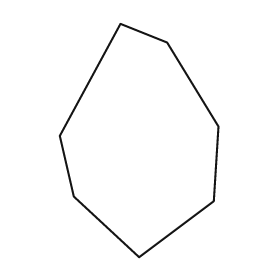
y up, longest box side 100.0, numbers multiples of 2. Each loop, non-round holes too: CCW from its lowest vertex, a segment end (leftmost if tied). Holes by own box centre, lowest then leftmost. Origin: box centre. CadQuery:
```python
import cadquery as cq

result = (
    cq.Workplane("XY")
    .moveTo(0.0, -50.0)
    .lineTo(32.0, -26.0)
    .lineTo(34.0, 6.0)
    .lineTo(12.0, 42.0)
    .lineTo(-8.0, 50.0)
    .lineTo(-34.0, 2.0)
    .lineTo(-28.0, -24.0)
    .close()
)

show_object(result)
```